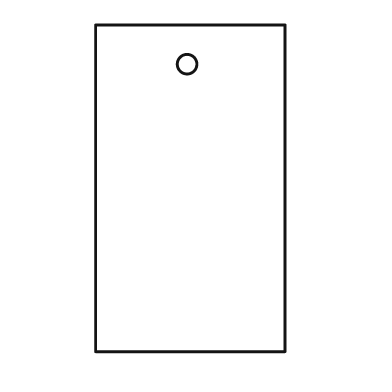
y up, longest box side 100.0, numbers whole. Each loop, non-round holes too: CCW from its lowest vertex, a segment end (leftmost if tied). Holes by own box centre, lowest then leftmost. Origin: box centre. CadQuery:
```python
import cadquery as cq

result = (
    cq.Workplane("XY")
    .moveTo(-29.0, -50.0)
    .lineTo(29.0, -50.0)
    .lineTo(29.0, 50.0)
    .lineTo(-29.0, 50.0)
    .close()
    .moveTo(-1.0, 38.0)
    .circle(3.0)
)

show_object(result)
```